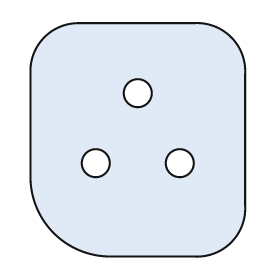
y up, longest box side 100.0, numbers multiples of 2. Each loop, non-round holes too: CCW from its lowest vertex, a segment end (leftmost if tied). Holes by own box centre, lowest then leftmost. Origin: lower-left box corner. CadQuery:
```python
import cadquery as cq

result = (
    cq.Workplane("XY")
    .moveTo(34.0, 0.0)
    .lineTo(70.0, 0.0)
    .threePointArc((86.0, 6.0), (92.0, 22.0))
    .lineTo(92.0, 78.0)
    .threePointArc((86.0, 94.0), (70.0, 100.0))
    .lineTo(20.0, 100.0)
    .threePointArc((6.0, 94.0), (0.0, 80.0))
    .lineTo(0.0, 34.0)
    .threePointArc((10.0, 10.0), (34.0, 0.0))
    .close()
    .moveTo(28.0, 40.0)
    .circle(6.0)
    .moveTo(64.0, 40.0)
    .circle(6.0)
    .moveTo(46.0, 70.0)
    .circle(6.0)
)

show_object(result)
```